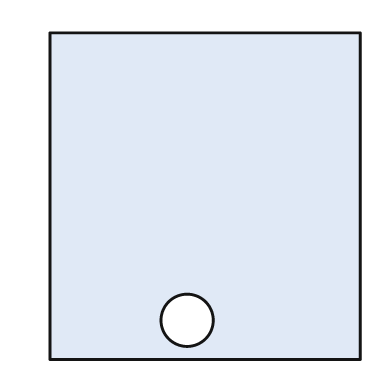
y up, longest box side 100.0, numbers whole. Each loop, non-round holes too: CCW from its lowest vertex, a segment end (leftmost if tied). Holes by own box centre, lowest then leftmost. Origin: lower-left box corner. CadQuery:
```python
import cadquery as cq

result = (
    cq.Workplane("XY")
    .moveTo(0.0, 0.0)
    .lineTo(95.0, 0.0)
    .lineTo(95.0, 100.0)
    .lineTo(0.0, 100.0)
    .close()
    .moveTo(42.0, 12.0)
    .circle(8.0)
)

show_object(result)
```